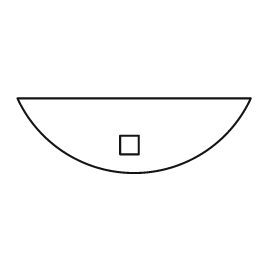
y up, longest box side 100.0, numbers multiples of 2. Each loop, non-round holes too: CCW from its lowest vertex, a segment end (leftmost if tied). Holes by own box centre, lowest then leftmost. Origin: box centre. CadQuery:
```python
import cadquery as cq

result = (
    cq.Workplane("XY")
    .moveTo(-50.0, 16.0)
    .threePointArc((0.0, -16.0), (50.0, 16.0))
    .close()
    .moveTo(-6.0, -8.0)
    .lineTo(2.0, -8.0)
    .lineTo(2.0, 0.0)
    .lineTo(-6.0, 0.0)
    .close()
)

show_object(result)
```